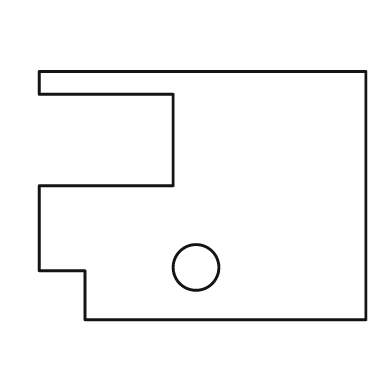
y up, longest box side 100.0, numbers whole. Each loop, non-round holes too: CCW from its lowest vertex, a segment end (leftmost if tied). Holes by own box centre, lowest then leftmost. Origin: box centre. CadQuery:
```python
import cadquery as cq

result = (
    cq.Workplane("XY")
    .moveTo(-36.0, -38.0)
    .lineTo(50.0, -38.0)
    .lineTo(50.0, 38.0)
    .lineTo(-50.0, 38.0)
    .lineTo(-50.0, 31.0)
    .lineTo(-9.0, 31.0)
    .lineTo(-9.0, 3.0)
    .lineTo(-50.0, 3.0)
    .lineTo(-50.0, -23.0)
    .lineTo(-36.0, -23.0)
    .close()
    .moveTo(-2.0, -22.0)
    .circle(7.0)
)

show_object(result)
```